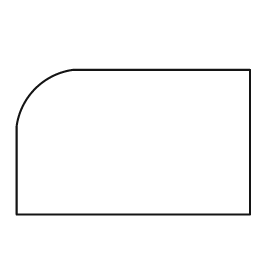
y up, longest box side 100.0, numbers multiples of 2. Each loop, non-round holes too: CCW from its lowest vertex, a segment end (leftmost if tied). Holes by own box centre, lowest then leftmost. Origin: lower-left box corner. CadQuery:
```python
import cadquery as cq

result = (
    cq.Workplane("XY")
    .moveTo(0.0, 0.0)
    .lineTo(100.0, 0.0)
    .lineTo(100.0, 62.0)
    .lineTo(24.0, 62.0)
    .threePointArc((8.0, 54.0), (0.0, 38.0))
    .close()
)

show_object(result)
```